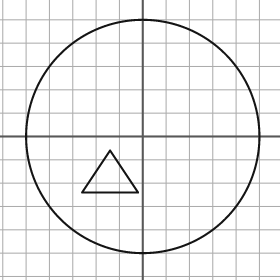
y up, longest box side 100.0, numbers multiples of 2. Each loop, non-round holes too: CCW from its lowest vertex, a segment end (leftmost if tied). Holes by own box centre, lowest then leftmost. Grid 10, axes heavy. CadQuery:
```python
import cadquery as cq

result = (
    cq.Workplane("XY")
    .moveTo(0.0, 0.0)
    .circle(50.0)
    .moveTo(-26.0, -24.0)
    .lineTo(-2.0, -24.0)
    .lineTo(-14.0, -6.0)
    .close()
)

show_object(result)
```